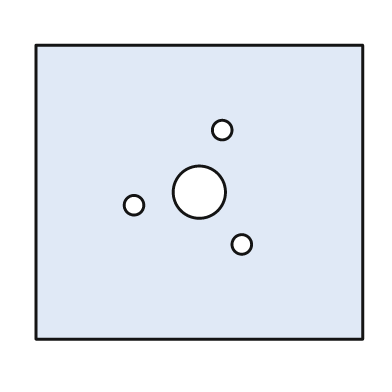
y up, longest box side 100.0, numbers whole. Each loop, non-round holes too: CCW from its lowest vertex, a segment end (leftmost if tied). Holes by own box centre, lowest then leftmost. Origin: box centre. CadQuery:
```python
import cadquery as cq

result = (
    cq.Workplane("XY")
    .moveTo(-50.0, -45.0)
    .lineTo(50.0, -45.0)
    .lineTo(50.0, 45.0)
    .lineTo(-50.0, 45.0)
    .close()
    .moveTo(13.0, -16.0)
    .circle(3.0)
    .moveTo(-20.0, -4.0)
    .circle(3.0)
    .moveTo(0.0, 0.0)
    .circle(8.0)
    .moveTo(7.0, 19.0)
    .circle(3.0)
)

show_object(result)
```